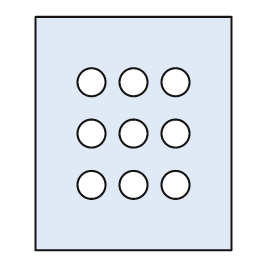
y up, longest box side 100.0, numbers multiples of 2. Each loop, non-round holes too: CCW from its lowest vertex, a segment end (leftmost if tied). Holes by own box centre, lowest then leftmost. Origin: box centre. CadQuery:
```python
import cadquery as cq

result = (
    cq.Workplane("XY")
    .moveTo(-42.0, -50.0)
    .lineTo(42.0, -50.0)
    .lineTo(42.0, 50.0)
    .lineTo(-42.0, 50.0)
    .close()
    .moveTo(-18.0, -22.0)
    .circle(6.0)
    .moveTo(0.0, -22.0)
    .circle(6.0)
    .moveTo(18.0, -22.0)
    .circle(6.0)
    .moveTo(-18.0, 0.0)
    .circle(6.0)
    .moveTo(0.0, 0.0)
    .circle(6.0)
    .moveTo(18.0, 0.0)
    .circle(6.0)
    .moveTo(-18.0, 22.0)
    .circle(6.0)
    .moveTo(0.0, 22.0)
    .circle(6.0)
    .moveTo(18.0, 22.0)
    .circle(6.0)
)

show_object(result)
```